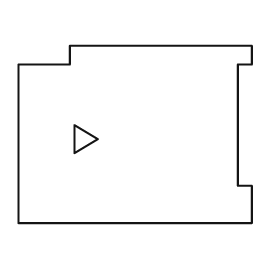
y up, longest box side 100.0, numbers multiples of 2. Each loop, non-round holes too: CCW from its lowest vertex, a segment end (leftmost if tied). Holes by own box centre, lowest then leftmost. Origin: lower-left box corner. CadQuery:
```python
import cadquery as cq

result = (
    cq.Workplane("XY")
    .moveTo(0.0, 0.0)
    .lineTo(100.0, 0.0)
    .lineTo(100.0, 16.0)
    .lineTo(94.0, 16.0)
    .lineTo(94.0, 68.0)
    .lineTo(100.0, 68.0)
    .lineTo(100.0, 76.0)
    .lineTo(22.0, 76.0)
    .lineTo(22.0, 68.0)
    .lineTo(0.0, 68.0)
    .close()
    .moveTo(24.0, 30.0)
    .lineTo(34.0, 36.0)
    .lineTo(24.0, 42.0)
    .close()
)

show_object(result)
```